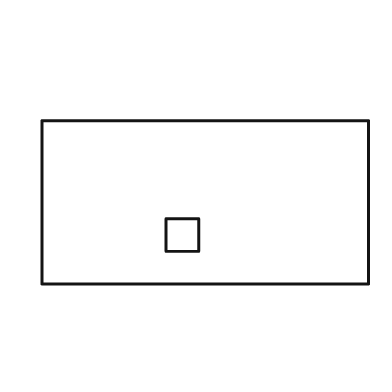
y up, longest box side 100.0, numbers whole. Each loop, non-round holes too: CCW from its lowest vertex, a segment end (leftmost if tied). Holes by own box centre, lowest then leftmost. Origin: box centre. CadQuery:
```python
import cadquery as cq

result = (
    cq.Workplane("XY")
    .moveTo(-50.0, -25.0)
    .lineTo(50.0, -25.0)
    .lineTo(50.0, 25.0)
    .lineTo(-50.0, 25.0)
    .close()
    .moveTo(-12.0, -15.0)
    .lineTo(-2.0, -15.0)
    .lineTo(-2.0, -5.0)
    .lineTo(-12.0, -5.0)
    .close()
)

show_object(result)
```